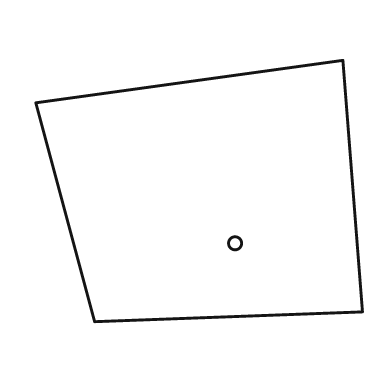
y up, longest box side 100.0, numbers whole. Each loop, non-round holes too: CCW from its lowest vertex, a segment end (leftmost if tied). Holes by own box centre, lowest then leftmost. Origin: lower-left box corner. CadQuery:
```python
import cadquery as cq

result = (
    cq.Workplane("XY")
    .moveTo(18.0, 0.0)
    .lineTo(100.0, 3.0)
    .lineTo(94.0, 80.0)
    .lineTo(0.0, 67.0)
    .close()
    .moveTo(61.0, 24.0)
    .circle(2.0)
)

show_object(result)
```